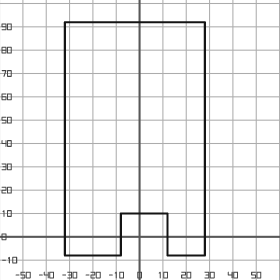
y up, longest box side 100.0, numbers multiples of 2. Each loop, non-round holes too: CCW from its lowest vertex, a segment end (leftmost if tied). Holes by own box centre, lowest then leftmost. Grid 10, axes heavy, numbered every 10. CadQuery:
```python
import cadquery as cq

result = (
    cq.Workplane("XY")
    .moveTo(-32.0, -8.0)
    .lineTo(-8.0, -8.0)
    .lineTo(-8.0, 10.0)
    .lineTo(12.0, 10.0)
    .lineTo(12.0, -8.0)
    .lineTo(28.0, -8.0)
    .lineTo(28.0, 92.0)
    .lineTo(-32.0, 92.0)
    .close()
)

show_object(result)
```